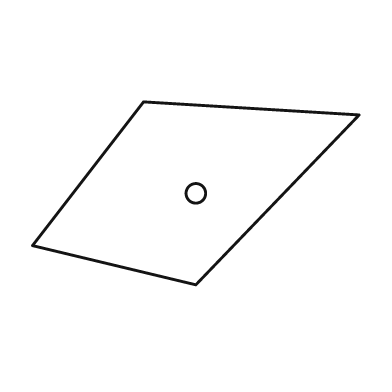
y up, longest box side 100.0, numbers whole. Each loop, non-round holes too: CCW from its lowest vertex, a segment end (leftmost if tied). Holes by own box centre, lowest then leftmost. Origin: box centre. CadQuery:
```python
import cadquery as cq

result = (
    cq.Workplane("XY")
    .moveTo(0.0, -28.0)
    .lineTo(50.0, 24.0)
    .lineTo(-16.0, 28.0)
    .lineTo(-50.0, -16.0)
    .close()
    .moveTo(0.0, 0.0)
    .circle(3.0)
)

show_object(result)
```